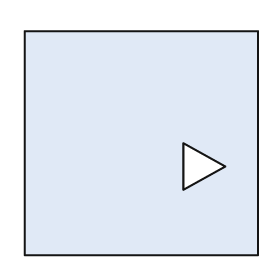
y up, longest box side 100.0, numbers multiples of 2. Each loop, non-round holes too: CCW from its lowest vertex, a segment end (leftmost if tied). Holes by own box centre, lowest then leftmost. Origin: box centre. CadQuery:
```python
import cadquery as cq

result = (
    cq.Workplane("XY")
    .moveTo(-50.0, -48.0)
    .lineTo(50.0, -48.0)
    .lineTo(50.0, 48.0)
    .lineTo(-50.0, 48.0)
    .close()
    .moveTo(18.0, -20.0)
    .lineTo(36.0, -10.0)
    .lineTo(18.0, 0.0)
    .close()
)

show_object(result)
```